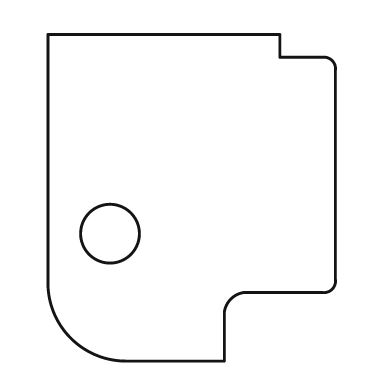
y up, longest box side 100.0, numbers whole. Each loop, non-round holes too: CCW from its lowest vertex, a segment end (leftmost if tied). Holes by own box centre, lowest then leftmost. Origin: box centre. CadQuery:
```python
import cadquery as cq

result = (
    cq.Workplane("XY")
    .moveTo(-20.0, -50.0)
    .lineTo(10.0, -50.0)
    .lineTo(10.0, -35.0)
    .threePointArc((12.0, -31.0), (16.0, -29.0))
    .lineTo(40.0, -29.0)
    .threePointArc((43.0, -28.0), (44.0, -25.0))
    .lineTo(44.0, 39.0)
    .threePointArc((43.0, 42.0), (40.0, 43.0))
    .lineTo(27.0, 43.0)
    .lineTo(27.0, 50.0)
    .lineTo(-44.0, 50.0)
    .lineTo(-44.0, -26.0)
    .threePointArc((-37.0, -43.0), (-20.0, -50.0))
    .close()
    .moveTo(-25.0, -11.0)
    .circle(9.0)
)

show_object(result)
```